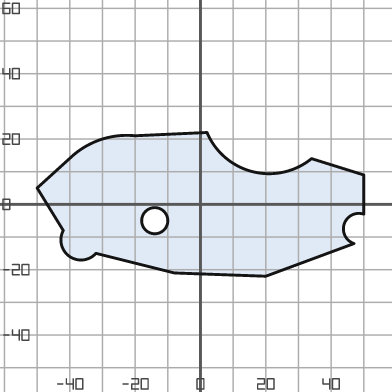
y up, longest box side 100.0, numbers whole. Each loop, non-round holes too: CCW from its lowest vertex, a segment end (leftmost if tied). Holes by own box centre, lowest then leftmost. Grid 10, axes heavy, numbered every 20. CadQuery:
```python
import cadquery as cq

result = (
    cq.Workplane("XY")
    .moveTo(20.0, -22.0)
    .lineTo(47.0, -12.0)
    .threePointArc((44.0, -6.0), (50.0, -3.0))
    .lineTo(50.0, 9.0)
    .lineTo(34.0, 14.0)
    .threePointArc((16.0, 10.0), (2.0, 22.0))
    .lineTo(-20.0, 21.0)
    .threePointArc((-30.0, 20.0), (-39.0, 15.0))
    .lineTo(-50.0, 5.0)
    .lineTo(-42.0, -8.0)
    .threePointArc((-40.0, -16.0), (-32.0, -15.0))
    .lineTo(-8.0, -21.0)
    .close()
    .moveTo(-14.0, -5.0)
    .circle(4.0)
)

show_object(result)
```